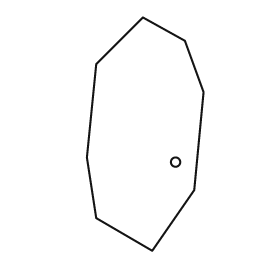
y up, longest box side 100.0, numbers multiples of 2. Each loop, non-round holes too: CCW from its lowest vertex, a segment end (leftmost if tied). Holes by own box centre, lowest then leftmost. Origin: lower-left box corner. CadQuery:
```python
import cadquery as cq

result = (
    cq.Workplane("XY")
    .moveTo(28.0, 0.0)
    .lineTo(46.0, 26.0)
    .lineTo(50.0, 68.0)
    .lineTo(42.0, 90.0)
    .lineTo(24.0, 100.0)
    .lineTo(4.0, 80.0)
    .lineTo(0.0, 40.0)
    .lineTo(4.0, 14.0)
    .close()
    .moveTo(38.0, 38.0)
    .circle(2.0)
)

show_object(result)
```